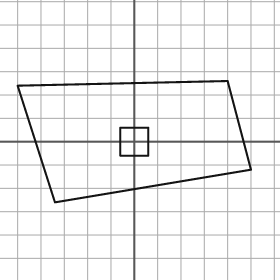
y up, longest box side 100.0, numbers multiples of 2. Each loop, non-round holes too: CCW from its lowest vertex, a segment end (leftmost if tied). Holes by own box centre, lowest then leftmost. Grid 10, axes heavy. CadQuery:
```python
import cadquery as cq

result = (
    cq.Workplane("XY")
    .moveTo(-34.0, -26.0)
    .lineTo(50.0, -12.0)
    .lineTo(40.0, 26.0)
    .lineTo(-50.0, 24.0)
    .close()
    .moveTo(-6.0, -6.0)
    .lineTo(6.0, -6.0)
    .lineTo(6.0, 6.0)
    .lineTo(-6.0, 6.0)
    .close()
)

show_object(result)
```